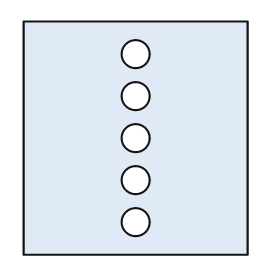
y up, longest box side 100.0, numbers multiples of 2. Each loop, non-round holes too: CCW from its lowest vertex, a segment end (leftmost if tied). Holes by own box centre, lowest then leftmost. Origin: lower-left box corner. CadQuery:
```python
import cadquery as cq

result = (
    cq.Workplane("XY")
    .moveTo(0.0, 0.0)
    .lineTo(96.0, 0.0)
    .lineTo(96.0, 100.0)
    .lineTo(0.0, 100.0)
    .close()
    .moveTo(48.0, 14.0)
    .circle(6.0)
    .moveTo(48.0, 32.0)
    .circle(6.0)
    .moveTo(48.0, 50.0)
    .circle(6.0)
    .moveTo(48.0, 68.0)
    .circle(6.0)
    .moveTo(48.0, 86.0)
    .circle(6.0)
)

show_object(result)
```